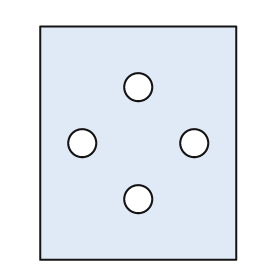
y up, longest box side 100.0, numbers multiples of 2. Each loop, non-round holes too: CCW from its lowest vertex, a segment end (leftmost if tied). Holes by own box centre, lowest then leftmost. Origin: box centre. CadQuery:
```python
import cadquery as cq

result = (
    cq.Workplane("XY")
    .moveTo(-42.0, -50.0)
    .lineTo(42.0, -50.0)
    .lineTo(42.0, 50.0)
    .lineTo(-42.0, 50.0)
    .close()
    .moveTo(0.0, -24.0)
    .circle(6.0)
    .moveTo(-24.0, 0.0)
    .circle(6.0)
    .moveTo(24.0, 0.0)
    .circle(6.0)
    .moveTo(0.0, 24.0)
    .circle(6.0)
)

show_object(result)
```